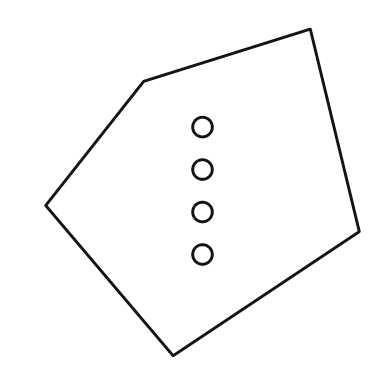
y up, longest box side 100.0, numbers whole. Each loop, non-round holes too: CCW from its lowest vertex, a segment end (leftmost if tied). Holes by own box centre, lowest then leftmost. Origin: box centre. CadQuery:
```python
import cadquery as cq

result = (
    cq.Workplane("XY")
    .moveTo(-9.0, -50.0)
    .lineTo(48.0, -12.0)
    .lineTo(33.0, 50.0)
    .lineTo(-18.0, 34.0)
    .lineTo(-48.0, -4.0)
    .close()
    .moveTo(0.0, -19.0)
    .circle(3.0)
    .moveTo(0.0, -6.0)
    .circle(3.0)
    .moveTo(0.0, 7.0)
    .circle(3.0)
    .moveTo(0.0, 20.0)
    .circle(3.0)
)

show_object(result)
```